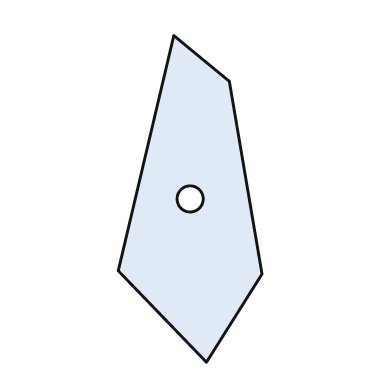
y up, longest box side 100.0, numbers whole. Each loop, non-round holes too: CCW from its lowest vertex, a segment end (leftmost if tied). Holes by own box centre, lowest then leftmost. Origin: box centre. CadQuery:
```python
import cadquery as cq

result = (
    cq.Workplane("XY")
    .moveTo(5.0, -50.0)
    .lineTo(22.0, -23.0)
    .lineTo(12.0, 36.0)
    .lineTo(-5.0, 50.0)
    .lineTo(-22.0, -22.0)
    .close()
    .moveTo(0.0, 0.0)
    .circle(4.0)
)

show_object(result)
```